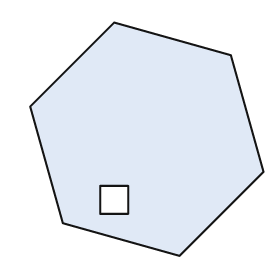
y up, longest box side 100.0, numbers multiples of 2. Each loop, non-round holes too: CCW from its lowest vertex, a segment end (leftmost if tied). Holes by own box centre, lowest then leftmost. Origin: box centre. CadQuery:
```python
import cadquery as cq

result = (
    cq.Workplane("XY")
    .moveTo(14.0, -50.0)
    .lineTo(50.0, -14.0)
    .lineTo(36.0, 36.0)
    .lineTo(-14.0, 50.0)
    .lineTo(-50.0, 14.0)
    .lineTo(-36.0, -36.0)
    .close()
    .moveTo(-20.0, -32.0)
    .lineTo(-8.0, -32.0)
    .lineTo(-8.0, -20.0)
    .lineTo(-20.0, -20.0)
    .close()
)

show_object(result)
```